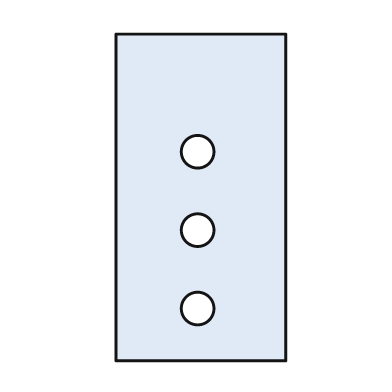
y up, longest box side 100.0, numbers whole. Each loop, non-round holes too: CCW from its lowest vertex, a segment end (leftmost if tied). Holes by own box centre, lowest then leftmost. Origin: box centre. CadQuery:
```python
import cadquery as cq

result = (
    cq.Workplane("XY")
    .moveTo(-26.0, -50.0)
    .lineTo(26.0, -50.0)
    .lineTo(26.0, 50.0)
    .lineTo(-26.0, 50.0)
    .close()
    .moveTo(-1.0, -34.0)
    .circle(5.0)
    .moveTo(-1.0, -10.0)
    .circle(5.0)
    .moveTo(-1.0, 14.0)
    .circle(5.0)
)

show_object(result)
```